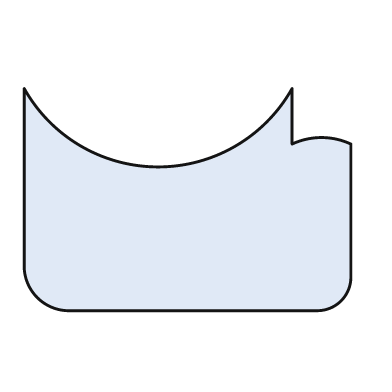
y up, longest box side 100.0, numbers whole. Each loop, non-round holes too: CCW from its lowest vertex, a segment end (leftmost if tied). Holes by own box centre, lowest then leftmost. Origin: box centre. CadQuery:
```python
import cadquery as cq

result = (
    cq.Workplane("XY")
    .moveTo(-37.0, -34.0)
    .lineTo(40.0, -34.0)
    .threePointArc((47.0, -31.0), (50.0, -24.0))
    .lineTo(50.0, 17.0)
    .threePointArc((41.0, 19.0), (32.0, 17.0))
    .lineTo(32.0, 34.0)
    .threePointArc((-9.0, 10.0), (-50.0, 34.0))
    .lineTo(-50.0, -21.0)
    .threePointArc((-46.0, -30.0), (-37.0, -34.0))
    .close()
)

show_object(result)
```